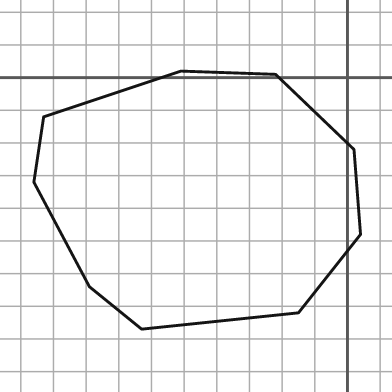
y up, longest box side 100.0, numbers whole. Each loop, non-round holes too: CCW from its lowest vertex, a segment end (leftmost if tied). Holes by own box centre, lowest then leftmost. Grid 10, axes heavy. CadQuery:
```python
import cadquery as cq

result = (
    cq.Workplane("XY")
    .moveTo(-63.0, -77.0)
    .lineTo(-15.0, -72.0)
    .lineTo(4.0, -48.0)
    .lineTo(2.0, -22.0)
    .lineTo(-22.0, 1.0)
    .lineTo(-51.0, 2.0)
    .lineTo(-93.0, -12.0)
    .lineTo(-96.0, -32.0)
    .lineTo(-79.0, -64.0)
    .close()
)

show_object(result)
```